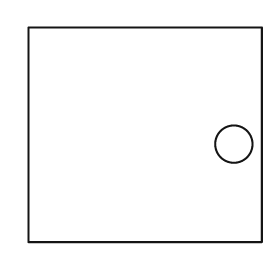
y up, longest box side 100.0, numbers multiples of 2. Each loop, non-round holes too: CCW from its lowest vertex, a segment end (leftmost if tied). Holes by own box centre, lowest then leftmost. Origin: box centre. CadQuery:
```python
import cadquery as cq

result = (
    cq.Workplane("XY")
    .moveTo(-50.0, -46.0)
    .lineTo(50.0, -46.0)
    .lineTo(50.0, 46.0)
    .lineTo(-50.0, 46.0)
    .close()
    .moveTo(38.0, -4.0)
    .circle(8.0)
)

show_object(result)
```